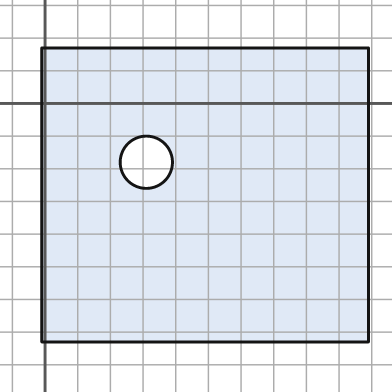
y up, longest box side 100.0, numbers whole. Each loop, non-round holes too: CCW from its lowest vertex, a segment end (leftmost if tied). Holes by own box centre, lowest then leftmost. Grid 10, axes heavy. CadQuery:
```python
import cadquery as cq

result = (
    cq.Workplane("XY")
    .moveTo(-1.0, -73.0)
    .lineTo(99.0, -73.0)
    .lineTo(99.0, 17.0)
    .lineTo(-1.0, 17.0)
    .close()
    .moveTo(31.0, -18.0)
    .circle(8.0)
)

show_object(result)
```